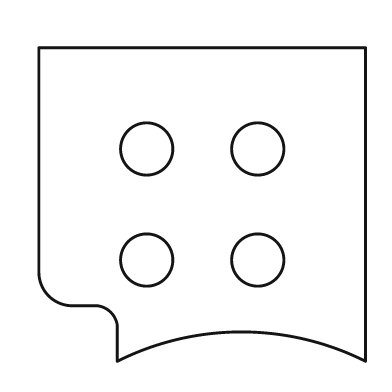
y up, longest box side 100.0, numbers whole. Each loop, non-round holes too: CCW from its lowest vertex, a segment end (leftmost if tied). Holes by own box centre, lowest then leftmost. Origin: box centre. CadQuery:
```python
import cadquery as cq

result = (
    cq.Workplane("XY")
    .moveTo(-26.0, -48.0)
    .threePointArc((12.0, -39.0), (50.0, -48.0))
    .lineTo(50.0, 48.0)
    .lineTo(-50.0, 48.0)
    .lineTo(-50.0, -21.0)
    .threePointArc((-47.0, -28.0), (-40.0, -31.0))
    .lineTo(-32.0, -31.0)
    .threePointArc((-28.0, -33.0), (-26.0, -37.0))
    .close()
    .moveTo(-17.0, -17.0)
    .circle(8.0)
    .moveTo(17.0, -17.0)
    .circle(8.0)
    .moveTo(-17.0, 17.0)
    .circle(8.0)
    .moveTo(17.0, 17.0)
    .circle(8.0)
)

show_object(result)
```